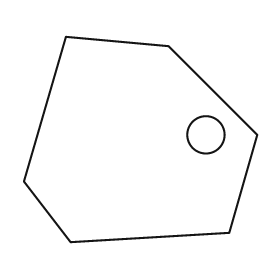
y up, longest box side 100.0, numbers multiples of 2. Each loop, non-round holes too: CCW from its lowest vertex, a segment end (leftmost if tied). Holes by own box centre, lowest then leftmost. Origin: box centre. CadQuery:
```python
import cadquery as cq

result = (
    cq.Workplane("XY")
    .moveTo(-30.0, -44.0)
    .lineTo(38.0, -40.0)
    .lineTo(50.0, 2.0)
    .lineTo(12.0, 40.0)
    .lineTo(-32.0, 44.0)
    .lineTo(-50.0, -18.0)
    .close()
    .moveTo(28.0, 2.0)
    .circle(8.0)
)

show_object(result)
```